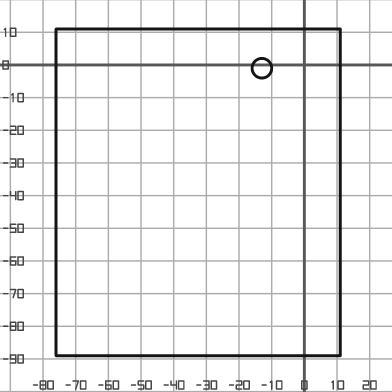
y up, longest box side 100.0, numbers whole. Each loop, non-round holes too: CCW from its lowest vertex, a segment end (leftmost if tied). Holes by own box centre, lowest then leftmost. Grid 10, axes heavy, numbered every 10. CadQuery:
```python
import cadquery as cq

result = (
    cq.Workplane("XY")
    .moveTo(-76.0, -89.0)
    .lineTo(11.0, -89.0)
    .lineTo(11.0, 11.0)
    .lineTo(-76.0, 11.0)
    .close()
    .moveTo(-13.0, -1.0)
    .circle(3.0)
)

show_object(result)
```